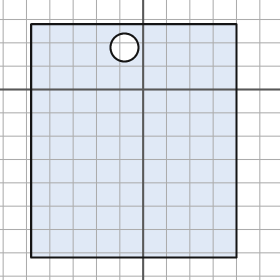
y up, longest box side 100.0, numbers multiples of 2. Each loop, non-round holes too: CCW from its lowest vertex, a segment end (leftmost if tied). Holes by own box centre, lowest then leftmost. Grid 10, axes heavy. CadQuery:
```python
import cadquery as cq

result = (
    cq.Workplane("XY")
    .moveTo(-48.0, -72.0)
    .lineTo(40.0, -72.0)
    .lineTo(40.0, 28.0)
    .lineTo(-48.0, 28.0)
    .close()
    .moveTo(-8.0, 18.0)
    .circle(6.0)
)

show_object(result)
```